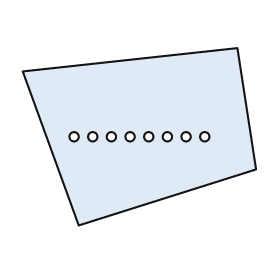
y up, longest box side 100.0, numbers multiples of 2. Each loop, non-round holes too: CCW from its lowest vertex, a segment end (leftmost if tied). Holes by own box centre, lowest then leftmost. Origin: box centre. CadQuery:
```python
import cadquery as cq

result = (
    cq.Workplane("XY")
    .moveTo(-26.0, -38.0)
    .lineTo(50.0, -14.0)
    .lineTo(42.0, 38.0)
    .lineTo(-50.0, 28.0)
    .close()
    .moveTo(-28.0, 0.0)
    .circle(2.0)
    .moveTo(-20.0, 0.0)
    .circle(2.0)
    .moveTo(-12.0, 0.0)
    .circle(2.0)
    .moveTo(-4.0, 0.0)
    .circle(2.0)
    .moveTo(4.0, 0.0)
    .circle(2.0)
    .moveTo(12.0, 0.0)
    .circle(2.0)
    .moveTo(20.0, 0.0)
    .circle(2.0)
    .moveTo(28.0, 0.0)
    .circle(2.0)
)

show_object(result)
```